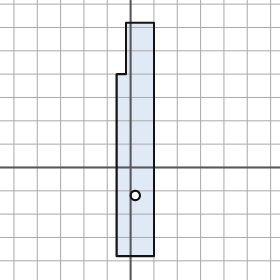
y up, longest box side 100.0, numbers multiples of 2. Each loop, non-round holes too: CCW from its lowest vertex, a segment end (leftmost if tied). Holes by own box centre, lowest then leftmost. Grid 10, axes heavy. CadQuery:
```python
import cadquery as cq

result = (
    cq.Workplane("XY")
    .moveTo(-6.0, -38.0)
    .lineTo(10.0, -38.0)
    .lineTo(10.0, 62.0)
    .lineTo(-2.0, 62.0)
    .lineTo(-2.0, 40.0)
    .lineTo(-6.0, 40.0)
    .close()
    .moveTo(2.0, -12.0)
    .circle(2.0)
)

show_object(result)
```